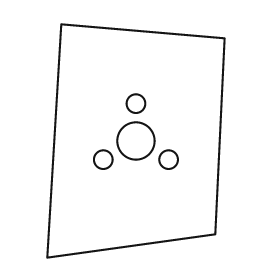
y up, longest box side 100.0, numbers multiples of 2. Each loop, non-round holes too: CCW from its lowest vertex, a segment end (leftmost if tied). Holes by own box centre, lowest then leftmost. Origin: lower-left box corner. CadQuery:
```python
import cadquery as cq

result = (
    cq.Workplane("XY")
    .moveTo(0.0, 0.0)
    .lineTo(72.0, 10.0)
    .lineTo(76.0, 94.0)
    .lineTo(6.0, 100.0)
    .close()
    .moveTo(24.0, 42.0)
    .circle(4.0)
    .moveTo(52.0, 42.0)
    .circle(4.0)
    .moveTo(38.0, 50.0)
    .circle(8.0)
    .moveTo(38.0, 66.0)
    .circle(4.0)
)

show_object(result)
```